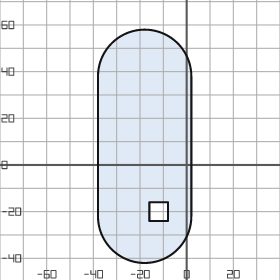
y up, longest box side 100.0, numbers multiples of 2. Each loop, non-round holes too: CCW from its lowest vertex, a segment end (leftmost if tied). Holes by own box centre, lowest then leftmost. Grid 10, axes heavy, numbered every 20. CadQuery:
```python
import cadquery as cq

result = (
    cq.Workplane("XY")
    .moveTo(-38.0, -22.0)
    .threePointArc((-18.0, -42.0), (2.0, -22.0))
    .lineTo(2.0, 38.0)
    .threePointArc((-18.0, 58.0), (-38.0, 38.0))
    .close()
    .moveTo(-16.0, -24.0)
    .lineTo(-8.0, -24.0)
    .lineTo(-8.0, -16.0)
    .lineTo(-16.0, -16.0)
    .close()
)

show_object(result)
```